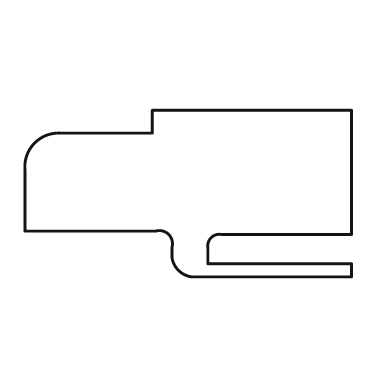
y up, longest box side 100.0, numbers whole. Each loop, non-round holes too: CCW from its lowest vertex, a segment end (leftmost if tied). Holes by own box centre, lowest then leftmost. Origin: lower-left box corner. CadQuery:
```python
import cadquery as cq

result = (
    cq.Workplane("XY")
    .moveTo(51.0, 0.0)
    .lineTo(100.0, 0.0)
    .lineTo(100.0, 4.0)
    .lineTo(56.0, 4.0)
    .lineTo(56.0, 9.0)
    .threePointArc((57.0, 12.0), (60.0, 13.0))
    .lineTo(100.0, 13.0)
    .lineTo(100.0, 51.0)
    .lineTo(39.0, 51.0)
    .lineTo(39.0, 44.0)
    .lineTo(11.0, 44.0)
    .threePointArc((3.0, 41.0), (0.0, 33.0))
    .lineTo(0.0, 14.0)
    .lineTo(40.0, 14.0)
    .threePointArc((44.0, 13.0), (45.0, 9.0))
    .lineTo(45.0, 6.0)
    .threePointArc((47.0, 2.0), (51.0, 0.0))
    .close()
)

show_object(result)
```